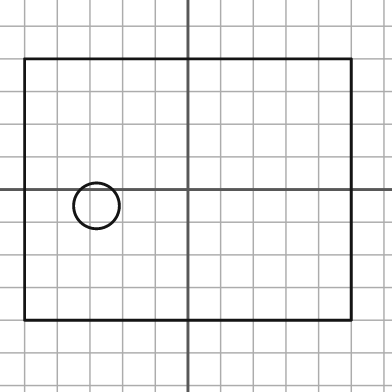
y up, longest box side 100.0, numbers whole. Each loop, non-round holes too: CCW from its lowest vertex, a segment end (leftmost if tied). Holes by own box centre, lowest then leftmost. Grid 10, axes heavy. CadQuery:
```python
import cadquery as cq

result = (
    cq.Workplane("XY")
    .moveTo(-50.0, -40.0)
    .lineTo(50.0, -40.0)
    .lineTo(50.0, 40.0)
    .lineTo(-50.0, 40.0)
    .close()
    .moveTo(-28.0, -5.0)
    .circle(7.0)
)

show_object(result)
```